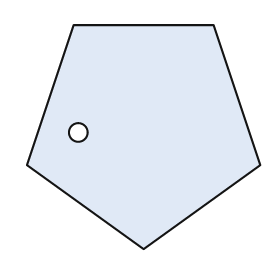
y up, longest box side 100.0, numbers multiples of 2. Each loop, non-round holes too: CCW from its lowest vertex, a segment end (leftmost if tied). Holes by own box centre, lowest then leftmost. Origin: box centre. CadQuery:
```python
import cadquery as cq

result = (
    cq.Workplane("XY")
    .moveTo(0.0, -48.0)
    .lineTo(50.0, -12.0)
    .lineTo(30.0, 48.0)
    .lineTo(-30.0, 48.0)
    .lineTo(-50.0, -12.0)
    .close()
    .moveTo(-28.0, 2.0)
    .circle(4.0)
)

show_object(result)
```